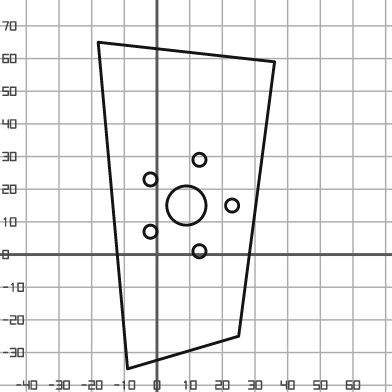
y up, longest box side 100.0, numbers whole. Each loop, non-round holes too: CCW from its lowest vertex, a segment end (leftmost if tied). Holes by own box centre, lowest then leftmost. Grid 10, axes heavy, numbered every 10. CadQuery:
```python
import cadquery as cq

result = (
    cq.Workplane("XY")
    .moveTo(-9.0, -35.0)
    .lineTo(25.0, -25.0)
    .lineTo(36.0, 59.0)
    .lineTo(-18.0, 65.0)
    .close()
    .moveTo(13.0, 1.0)
    .circle(2.0)
    .moveTo(-2.0, 7.0)
    .circle(2.0)
    .moveTo(9.0, 15.0)
    .circle(6.0)
    .moveTo(23.0, 15.0)
    .circle(2.0)
    .moveTo(-2.0, 23.0)
    .circle(2.0)
    .moveTo(13.0, 29.0)
    .circle(2.0)
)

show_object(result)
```